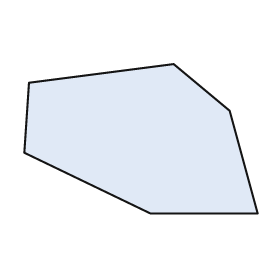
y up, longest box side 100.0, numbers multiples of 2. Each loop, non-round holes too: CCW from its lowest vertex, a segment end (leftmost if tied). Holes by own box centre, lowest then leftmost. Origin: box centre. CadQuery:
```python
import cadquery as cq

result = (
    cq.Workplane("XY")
    .moveTo(4.0, -32.0)
    .lineTo(50.0, -32.0)
    .lineTo(38.0, 12.0)
    .lineTo(14.0, 32.0)
    .lineTo(-48.0, 24.0)
    .lineTo(-50.0, -6.0)
    .close()
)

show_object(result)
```